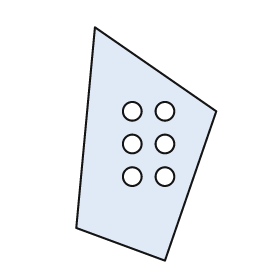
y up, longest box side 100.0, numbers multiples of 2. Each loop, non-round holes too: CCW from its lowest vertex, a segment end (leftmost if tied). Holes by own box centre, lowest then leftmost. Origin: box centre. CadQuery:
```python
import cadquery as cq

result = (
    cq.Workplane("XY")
    .moveTo(8.0, -50.0)
    .lineTo(30.0, 14.0)
    .lineTo(-22.0, 50.0)
    .lineTo(-30.0, -36.0)
    .close()
    .moveTo(-6.0, -14.0)
    .circle(4.0)
    .moveTo(8.0, -14.0)
    .circle(4.0)
    .moveTo(-6.0, 0.0)
    .circle(4.0)
    .moveTo(8.0, 0.0)
    .circle(4.0)
    .moveTo(-6.0, 14.0)
    .circle(4.0)
    .moveTo(8.0, 14.0)
    .circle(4.0)
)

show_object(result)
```